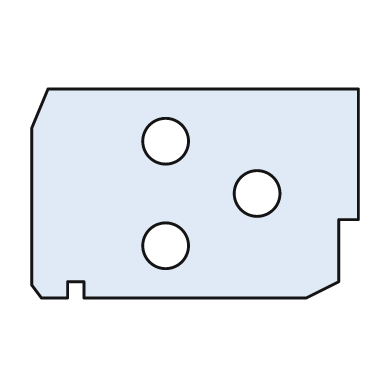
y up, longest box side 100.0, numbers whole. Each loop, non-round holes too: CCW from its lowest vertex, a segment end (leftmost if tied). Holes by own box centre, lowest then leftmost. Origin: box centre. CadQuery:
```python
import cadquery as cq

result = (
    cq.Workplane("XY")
    .moveTo(-47.0, -32.0)
    .lineTo(-39.0, -32.0)
    .lineTo(-39.0, -27.0)
    .lineTo(-34.0, -27.0)
    .lineTo(-34.0, -32.0)
    .lineTo(34.0, -32.0)
    .lineTo(44.0, -27.0)
    .lineTo(44.0, -8.0)
    .lineTo(50.0, -8.0)
    .lineTo(50.0, 32.0)
    .lineTo(-45.0, 32.0)
    .lineTo(-50.0, 20.0)
    .lineTo(-50.0, -28.0)
    .close()
    .moveTo(-9.0, -16.0)
    .circle(7.0)
    .moveTo(19.0, 0.0)
    .circle(7.0)
    .moveTo(-9.0, 16.0)
    .circle(7.0)
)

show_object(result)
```